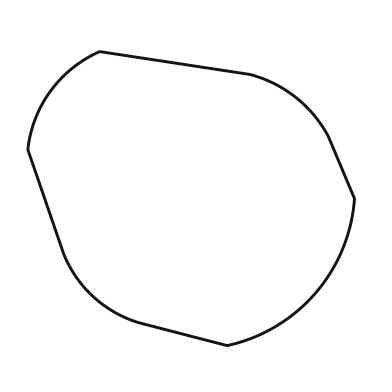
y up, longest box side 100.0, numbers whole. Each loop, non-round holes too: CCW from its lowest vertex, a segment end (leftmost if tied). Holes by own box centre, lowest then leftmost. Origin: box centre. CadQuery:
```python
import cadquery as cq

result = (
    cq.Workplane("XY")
    .moveTo(11.0, -45.0)
    .threePointArc((38.0, -29.0), (50.0, 0.0))
    .lineTo(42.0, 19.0)
    .threePointArc((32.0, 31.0), (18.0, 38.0))
    .lineTo(-28.0, 45.0)
    .threePointArc((-43.0, 33.0), (-50.0, 15.0))
    .lineTo(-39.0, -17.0)
    .threePointArc((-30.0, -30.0), (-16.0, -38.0))
    .close()
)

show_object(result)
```